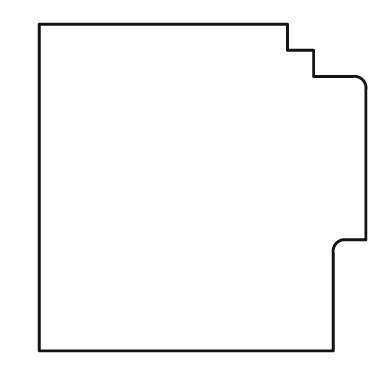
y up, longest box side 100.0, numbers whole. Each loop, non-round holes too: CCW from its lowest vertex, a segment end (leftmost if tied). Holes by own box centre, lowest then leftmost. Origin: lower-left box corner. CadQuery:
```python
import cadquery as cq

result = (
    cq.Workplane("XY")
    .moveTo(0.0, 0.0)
    .lineTo(90.0, 0.0)
    .lineTo(90.0, 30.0)
    .threePointArc((91.0, 33.0), (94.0, 34.0))
    .lineTo(100.0, 34.0)
    .lineTo(100.0, 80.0)
    .threePointArc((99.0, 83.0), (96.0, 84.0))
    .lineTo(84.0, 84.0)
    .lineTo(84.0, 92.0)
    .lineTo(76.0, 92.0)
    .lineTo(76.0, 100.0)
    .lineTo(0.0, 100.0)
    .close()
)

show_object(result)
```